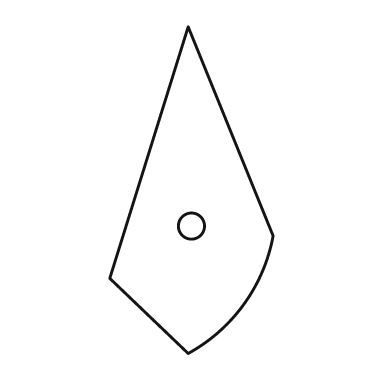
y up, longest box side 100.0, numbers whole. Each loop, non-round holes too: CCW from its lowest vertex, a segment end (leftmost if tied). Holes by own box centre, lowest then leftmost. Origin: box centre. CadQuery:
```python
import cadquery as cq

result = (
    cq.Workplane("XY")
    .moveTo(-1.0, -50.0)
    .threePointArc((16.0, -35.0), (25.0, -14.0))
    .lineTo(-1.0, 50.0)
    .lineTo(-25.0, -27.0)
    .close()
    .moveTo(0.0, -11.0)
    .circle(4.0)
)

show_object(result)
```